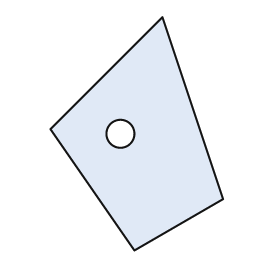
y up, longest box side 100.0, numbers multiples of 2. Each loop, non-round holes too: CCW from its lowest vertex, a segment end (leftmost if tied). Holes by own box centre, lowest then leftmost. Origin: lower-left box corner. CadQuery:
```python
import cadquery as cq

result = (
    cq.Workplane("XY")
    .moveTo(36.0, 0.0)
    .lineTo(74.0, 22.0)
    .lineTo(48.0, 100.0)
    .lineTo(0.0, 52.0)
    .close()
    .moveTo(30.0, 50.0)
    .circle(6.0)
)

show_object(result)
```